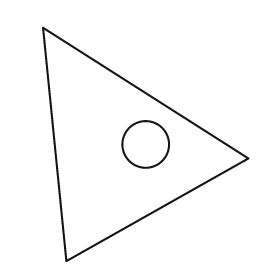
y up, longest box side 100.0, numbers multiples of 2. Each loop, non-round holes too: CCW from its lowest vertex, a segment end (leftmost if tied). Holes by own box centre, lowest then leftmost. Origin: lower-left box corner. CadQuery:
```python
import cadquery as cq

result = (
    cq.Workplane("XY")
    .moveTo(10.0, 0.0)
    .lineTo(88.0, 44.0)
    .lineTo(0.0, 100.0)
    .close()
    .moveTo(44.0, 50.0)
    .circle(10.0)
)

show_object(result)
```